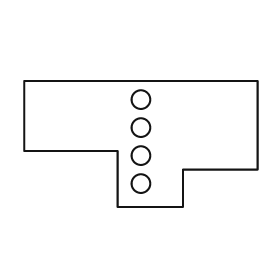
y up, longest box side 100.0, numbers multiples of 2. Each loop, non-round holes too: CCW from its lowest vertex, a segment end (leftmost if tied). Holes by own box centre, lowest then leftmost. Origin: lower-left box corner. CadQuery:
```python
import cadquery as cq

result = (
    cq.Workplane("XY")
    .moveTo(40.0, 0.0)
    .lineTo(68.0, 0.0)
    .lineTo(68.0, 16.0)
    .lineTo(100.0, 16.0)
    .lineTo(100.0, 54.0)
    .lineTo(0.0, 54.0)
    .lineTo(0.0, 24.0)
    .lineTo(40.0, 24.0)
    .close()
    .moveTo(50.0, 10.0)
    .circle(4.0)
    .moveTo(50.0, 22.0)
    .circle(4.0)
    .moveTo(50.0, 34.0)
    .circle(4.0)
    .moveTo(50.0, 46.0)
    .circle(4.0)
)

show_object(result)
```